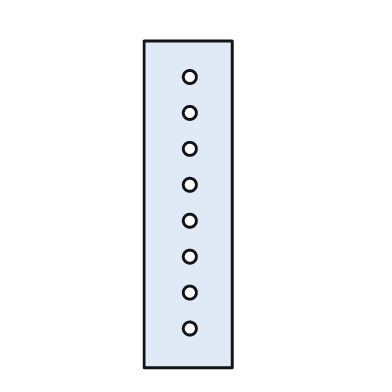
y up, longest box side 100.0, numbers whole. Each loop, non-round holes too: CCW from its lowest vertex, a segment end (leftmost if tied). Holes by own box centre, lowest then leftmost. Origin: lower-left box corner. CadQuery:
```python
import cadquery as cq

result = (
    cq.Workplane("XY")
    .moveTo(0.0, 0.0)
    .lineTo(27.0, 0.0)
    .lineTo(27.0, 100.0)
    .lineTo(0.0, 100.0)
    .close()
    .moveTo(14.0, 12.0)
    .circle(2.0)
    .moveTo(14.0, 23.0)
    .circle(2.0)
    .moveTo(14.0, 34.0)
    .circle(2.0)
    .moveTo(14.0, 45.0)
    .circle(2.0)
    .moveTo(14.0, 56.0)
    .circle(2.0)
    .moveTo(14.0, 67.0)
    .circle(2.0)
    .moveTo(14.0, 78.0)
    .circle(2.0)
    .moveTo(14.0, 89.0)
    .circle(2.0)
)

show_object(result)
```